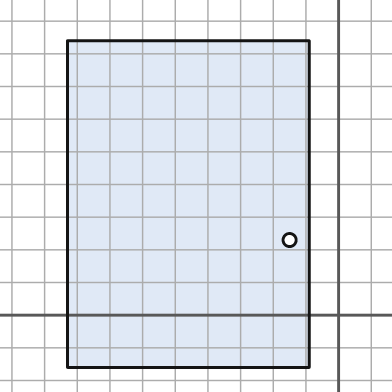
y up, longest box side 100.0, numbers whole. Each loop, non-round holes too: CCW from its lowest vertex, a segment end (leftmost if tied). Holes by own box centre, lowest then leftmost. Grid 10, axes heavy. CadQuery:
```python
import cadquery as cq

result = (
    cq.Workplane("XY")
    .moveTo(-83.0, -16.0)
    .lineTo(-9.0, -16.0)
    .lineTo(-9.0, 84.0)
    .lineTo(-83.0, 84.0)
    .close()
    .moveTo(-15.0, 23.0)
    .circle(2.0)
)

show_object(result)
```